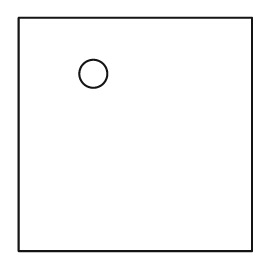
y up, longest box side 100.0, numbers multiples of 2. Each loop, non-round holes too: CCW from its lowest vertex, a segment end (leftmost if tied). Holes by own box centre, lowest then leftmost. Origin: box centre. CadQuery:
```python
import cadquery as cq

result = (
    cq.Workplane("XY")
    .moveTo(-50.0, -50.0)
    .lineTo(50.0, -50.0)
    .lineTo(50.0, 50.0)
    .lineTo(-50.0, 50.0)
    .close()
    .moveTo(-18.0, 26.0)
    .circle(6.0)
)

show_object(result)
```